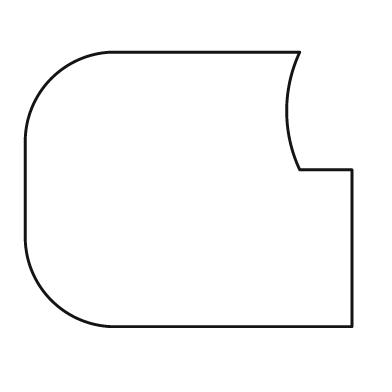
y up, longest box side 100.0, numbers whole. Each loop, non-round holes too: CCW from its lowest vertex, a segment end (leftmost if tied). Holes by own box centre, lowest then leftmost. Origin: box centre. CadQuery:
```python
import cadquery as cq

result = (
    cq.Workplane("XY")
    .moveTo(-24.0, -42.0)
    .lineTo(50.0, -42.0)
    .lineTo(50.0, 6.0)
    .lineTo(34.0, 6.0)
    .threePointArc((30.0, 24.0), (34.0, 42.0))
    .lineTo(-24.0, 42.0)
    .threePointArc((-42.0, 34.0), (-50.0, 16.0))
    .lineTo(-50.0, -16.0)
    .threePointArc((-42.0, -34.0), (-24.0, -42.0))
    .close()
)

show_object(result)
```